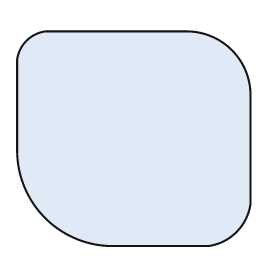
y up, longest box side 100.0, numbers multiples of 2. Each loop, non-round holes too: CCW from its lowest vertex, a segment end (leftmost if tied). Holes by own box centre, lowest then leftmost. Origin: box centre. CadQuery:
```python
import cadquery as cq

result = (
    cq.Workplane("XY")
    .moveTo(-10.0, -46.0)
    .lineTo(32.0, -46.0)
    .threePointArc((44.0, -40.0), (50.0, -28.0))
    .lineTo(50.0, 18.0)
    .threePointArc((42.0, 38.0), (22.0, 46.0))
    .lineTo(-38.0, 46.0)
    .threePointArc((-46.0, 42.0), (-50.0, 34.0))
    .lineTo(-50.0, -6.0)
    .threePointArc((-38.0, -34.0), (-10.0, -46.0))
    .close()
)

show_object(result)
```